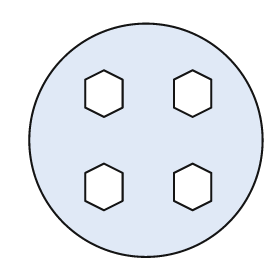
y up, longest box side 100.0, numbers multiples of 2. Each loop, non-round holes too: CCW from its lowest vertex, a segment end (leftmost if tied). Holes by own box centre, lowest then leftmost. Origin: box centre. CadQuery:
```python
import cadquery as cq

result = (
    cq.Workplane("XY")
    .moveTo(0.0, 0.0)
    .circle(50.0)
    .moveTo(-18.0, -30.0)
    .lineTo(-10.0, -26.0)
    .lineTo(-10.0, -14.0)
    .lineTo(-18.0, -10.0)
    .lineTo(-26.0, -14.0)
    .lineTo(-26.0, -26.0)
    .close()
    .moveTo(20.0, -30.0)
    .lineTo(28.0, -26.0)
    .lineTo(28.0, -14.0)
    .lineTo(20.0, -10.0)
    .lineTo(12.0, -14.0)
    .lineTo(12.0, -26.0)
    .close()
    .moveTo(-18.0, 10.0)
    .lineTo(-10.0, 14.0)
    .lineTo(-10.0, 26.0)
    .lineTo(-18.0, 30.0)
    .lineTo(-26.0, 26.0)
    .lineTo(-26.0, 14.0)
    .close()
    .moveTo(20.0, 10.0)
    .lineTo(28.0, 14.0)
    .lineTo(28.0, 26.0)
    .lineTo(20.0, 30.0)
    .lineTo(12.0, 26.0)
    .lineTo(12.0, 14.0)
    .close()
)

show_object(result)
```